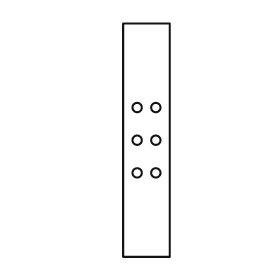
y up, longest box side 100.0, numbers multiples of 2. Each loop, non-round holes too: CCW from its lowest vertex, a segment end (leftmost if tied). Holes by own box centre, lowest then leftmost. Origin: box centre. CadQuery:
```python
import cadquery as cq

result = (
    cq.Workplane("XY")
    .moveTo(-10.0, -50.0)
    .lineTo(10.0, -50.0)
    .lineTo(10.0, 50.0)
    .lineTo(-10.0, 50.0)
    .close()
    .moveTo(-4.0, -14.0)
    .circle(2.0)
    .moveTo(4.0, -14.0)
    .circle(2.0)
    .moveTo(-4.0, 0.0)
    .circle(2.0)
    .moveTo(4.0, 0.0)
    .circle(2.0)
    .moveTo(-4.0, 14.0)
    .circle(2.0)
    .moveTo(4.0, 14.0)
    .circle(2.0)
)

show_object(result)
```